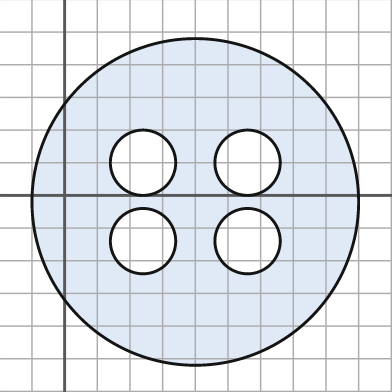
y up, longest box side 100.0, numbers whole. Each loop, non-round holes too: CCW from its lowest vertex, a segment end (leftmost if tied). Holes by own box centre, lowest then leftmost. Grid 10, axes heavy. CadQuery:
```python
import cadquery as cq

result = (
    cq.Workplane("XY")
    .moveTo(40.0, -2.0)
    .circle(50.0)
    .moveTo(24.0, -14.0)
    .circle(10.0)
    .moveTo(56.0, -14.0)
    .circle(10.0)
    .moveTo(24.0, 10.0)
    .circle(10.0)
    .moveTo(56.0, 10.0)
    .circle(10.0)
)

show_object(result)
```